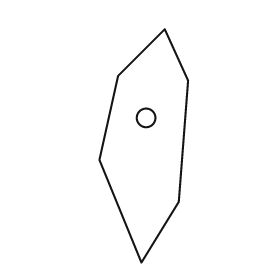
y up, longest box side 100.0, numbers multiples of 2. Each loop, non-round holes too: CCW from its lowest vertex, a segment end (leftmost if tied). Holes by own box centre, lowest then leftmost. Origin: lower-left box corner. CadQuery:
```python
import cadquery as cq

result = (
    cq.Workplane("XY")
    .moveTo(18.0, 0.0)
    .lineTo(34.0, 26.0)
    .lineTo(38.0, 78.0)
    .lineTo(28.0, 100.0)
    .lineTo(8.0, 80.0)
    .lineTo(0.0, 44.0)
    .close()
    .moveTo(20.0, 62.0)
    .circle(4.0)
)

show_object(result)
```